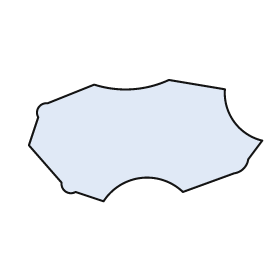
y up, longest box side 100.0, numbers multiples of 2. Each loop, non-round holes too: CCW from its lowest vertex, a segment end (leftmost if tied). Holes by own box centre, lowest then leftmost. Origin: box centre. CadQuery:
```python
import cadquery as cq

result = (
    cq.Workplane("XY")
    .moveTo(-18.0, -26.0)
    .threePointArc((-2.0, -16.0), (16.0, -22.0))
    .lineTo(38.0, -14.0)
    .threePointArc((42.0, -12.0), (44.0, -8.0))
    .lineTo(50.0, 0.0)
    .threePointArc((38.0, 8.0), (34.0, 22.0))
    .lineTo(10.0, 26.0)
    .threePointArc((-6.0, 22.0), (-22.0, 24.0))
    .lineTo(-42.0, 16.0)
    .threePointArc((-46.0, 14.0), (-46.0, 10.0))
    .lineTo(-50.0, -2.0)
    .lineTo(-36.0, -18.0)
    .threePointArc((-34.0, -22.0), (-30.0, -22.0))
    .close()
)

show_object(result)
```